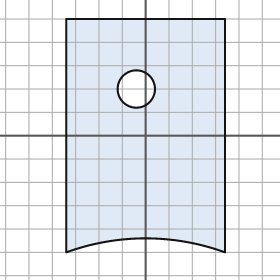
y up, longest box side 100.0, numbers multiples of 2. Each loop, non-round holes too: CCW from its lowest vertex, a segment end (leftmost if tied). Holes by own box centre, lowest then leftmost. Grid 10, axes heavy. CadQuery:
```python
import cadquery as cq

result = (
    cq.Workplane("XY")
    .moveTo(-34.0, -50.0)
    .threePointArc((0.0, -44.0), (34.0, -50.0))
    .lineTo(34.0, 50.0)
    .lineTo(-34.0, 50.0)
    .close()
    .moveTo(-4.0, 20.0)
    .circle(8.0)
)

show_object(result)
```